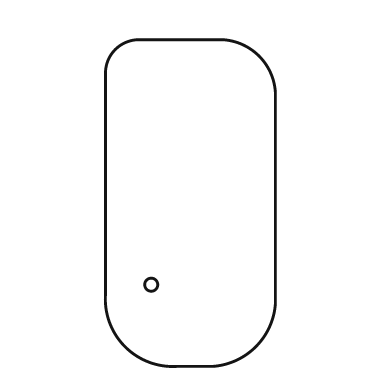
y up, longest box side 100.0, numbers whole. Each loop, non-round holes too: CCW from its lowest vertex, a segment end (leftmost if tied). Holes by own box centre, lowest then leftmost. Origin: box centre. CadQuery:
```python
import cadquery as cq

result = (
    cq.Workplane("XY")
    .moveTo(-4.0, -50.0)
    .lineTo(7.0, -50.0)
    .threePointArc((20.0, -44.0), (26.0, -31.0))
    .lineTo(26.0, 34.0)
    .threePointArc((21.0, 45.0), (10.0, 50.0))
    .lineTo(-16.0, 50.0)
    .threePointArc((-23.0, 47.0), (-26.0, 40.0))
    .lineTo(-26.0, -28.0)
    .threePointArc((-20.0, -44.0), (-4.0, -50.0))
    .close()
    .moveTo(-12.0, -25.0)
    .circle(2.0)
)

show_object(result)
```